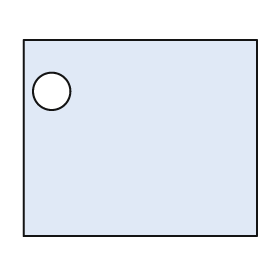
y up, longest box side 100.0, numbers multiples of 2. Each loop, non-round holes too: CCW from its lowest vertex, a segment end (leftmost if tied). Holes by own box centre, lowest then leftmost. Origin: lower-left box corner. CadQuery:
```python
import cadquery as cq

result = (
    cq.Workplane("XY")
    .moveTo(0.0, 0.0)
    .lineTo(100.0, 0.0)
    .lineTo(100.0, 84.0)
    .lineTo(0.0, 84.0)
    .close()
    .moveTo(12.0, 62.0)
    .circle(8.0)
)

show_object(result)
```